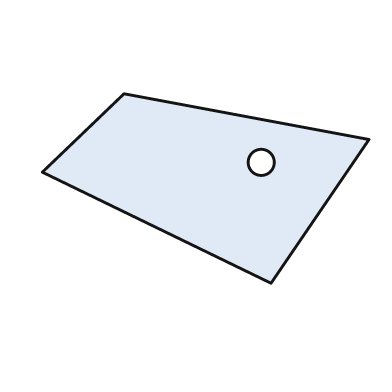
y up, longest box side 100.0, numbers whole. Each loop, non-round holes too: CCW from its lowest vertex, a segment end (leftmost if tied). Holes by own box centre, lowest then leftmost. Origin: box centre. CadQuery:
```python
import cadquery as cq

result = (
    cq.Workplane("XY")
    .moveTo(20.0, -29.0)
    .lineTo(50.0, 15.0)
    .lineTo(-25.0, 29.0)
    .lineTo(-50.0, 5.0)
    .close()
    .moveTo(17.0, 8.0)
    .circle(4.0)
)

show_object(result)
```